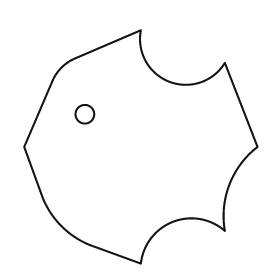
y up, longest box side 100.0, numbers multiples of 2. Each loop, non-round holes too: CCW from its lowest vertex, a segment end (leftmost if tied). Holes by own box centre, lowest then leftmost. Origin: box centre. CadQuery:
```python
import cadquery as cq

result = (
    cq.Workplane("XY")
    .moveTo(0.0, -50.0)
    .threePointArc((14.0, -32.0), (36.0, -36.0))
    .threePointArc((38.0, -16.0), (50.0, 0.0))
    .lineTo(36.0, 36.0)
    .threePointArc((12.0, 28.0), (0.0, 50.0))
    .lineTo(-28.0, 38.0)
    .threePointArc((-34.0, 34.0), (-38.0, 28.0))
    .lineTo(-50.0, 0.0)
    .lineTo(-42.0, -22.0)
    .threePointArc((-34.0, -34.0), (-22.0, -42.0))
    .close()
    .moveTo(-24.0, 14.0)
    .circle(4.0)
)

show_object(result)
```